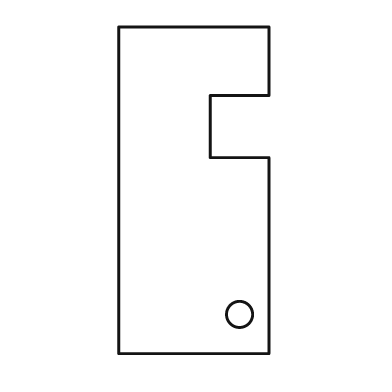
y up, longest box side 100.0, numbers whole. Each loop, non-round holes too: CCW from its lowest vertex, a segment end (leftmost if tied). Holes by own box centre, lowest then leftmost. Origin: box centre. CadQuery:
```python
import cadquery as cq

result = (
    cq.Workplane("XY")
    .moveTo(-23.0, -50.0)
    .lineTo(23.0, -50.0)
    .lineTo(23.0, 10.0)
    .lineTo(5.0, 10.0)
    .lineTo(5.0, 29.0)
    .lineTo(23.0, 29.0)
    .lineTo(23.0, 50.0)
    .lineTo(-23.0, 50.0)
    .close()
    .moveTo(14.0, -38.0)
    .circle(4.0)
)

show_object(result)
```